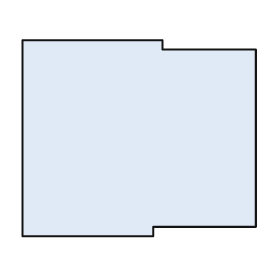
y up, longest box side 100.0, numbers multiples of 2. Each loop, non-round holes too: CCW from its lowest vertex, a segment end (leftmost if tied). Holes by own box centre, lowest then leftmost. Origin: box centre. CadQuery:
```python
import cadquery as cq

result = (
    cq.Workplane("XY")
    .moveTo(-50.0, -42.0)
    .lineTo(6.0, -42.0)
    .lineTo(6.0, -38.0)
    .lineTo(50.0, -38.0)
    .lineTo(50.0, 38.0)
    .lineTo(10.0, 38.0)
    .lineTo(10.0, 42.0)
    .lineTo(-50.0, 42.0)
    .close()
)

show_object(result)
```